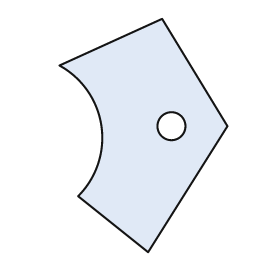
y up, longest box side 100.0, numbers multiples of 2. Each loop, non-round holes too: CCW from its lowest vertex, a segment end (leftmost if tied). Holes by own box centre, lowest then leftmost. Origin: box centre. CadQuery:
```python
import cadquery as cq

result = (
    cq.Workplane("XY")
    .moveTo(2.0, -50.0)
    .lineTo(36.0, 4.0)
    .lineTo(8.0, 50.0)
    .lineTo(-36.0, 30.0)
    .threePointArc((-18.0, 4.0), (-28.0, -26.0))
    .close()
    .moveTo(12.0, 4.0)
    .circle(6.0)
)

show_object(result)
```